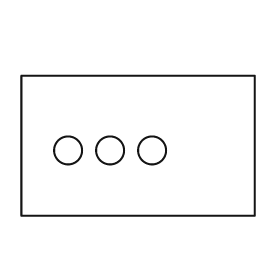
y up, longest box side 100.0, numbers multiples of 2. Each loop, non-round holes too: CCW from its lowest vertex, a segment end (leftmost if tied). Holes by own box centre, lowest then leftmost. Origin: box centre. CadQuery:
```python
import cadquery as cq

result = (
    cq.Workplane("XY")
    .moveTo(-50.0, -30.0)
    .lineTo(50.0, -30.0)
    .lineTo(50.0, 30.0)
    .lineTo(-50.0, 30.0)
    .close()
    .moveTo(-30.0, -2.0)
    .circle(6.0)
    .moveTo(-12.0, -2.0)
    .circle(6.0)
    .moveTo(6.0, -2.0)
    .circle(6.0)
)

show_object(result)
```